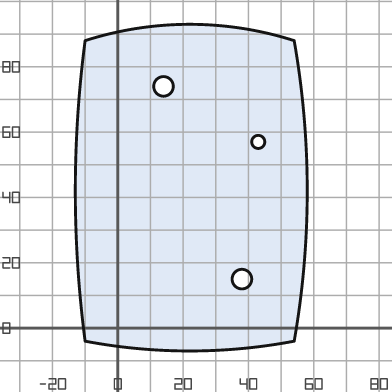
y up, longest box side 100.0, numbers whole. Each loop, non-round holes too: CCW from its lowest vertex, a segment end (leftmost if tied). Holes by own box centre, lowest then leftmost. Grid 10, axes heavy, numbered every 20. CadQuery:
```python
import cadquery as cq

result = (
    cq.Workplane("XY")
    .moveTo(-10.0, -4.0)
    .threePointArc((22.0, -7.0), (54.0, -4.0))
    .threePointArc((58.0, 42.0), (54.0, 88.0))
    .threePointArc((22.0, 93.0), (-10.0, 88.0))
    .threePointArc((-13.0, 42.0), (-10.0, -4.0))
    .close()
    .moveTo(38.0, 15.0)
    .circle(3.0)
    .moveTo(43.0, 57.0)
    .circle(2.0)
    .moveTo(14.0, 74.0)
    .circle(3.0)
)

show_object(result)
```